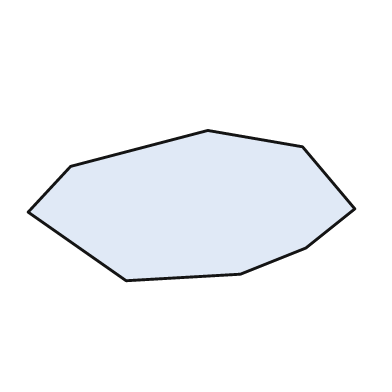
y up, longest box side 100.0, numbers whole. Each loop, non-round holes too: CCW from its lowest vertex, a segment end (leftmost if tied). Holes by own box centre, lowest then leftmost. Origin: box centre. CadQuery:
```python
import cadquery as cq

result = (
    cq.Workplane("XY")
    .moveTo(-20.0, -23.0)
    .lineTo(15.0, -21.0)
    .lineTo(35.0, -13.0)
    .lineTo(50.0, -1.0)
    .lineTo(34.0, 18.0)
    .lineTo(5.0, 23.0)
    .lineTo(-37.0, 12.0)
    .lineTo(-50.0, -2.0)
    .close()
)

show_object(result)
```